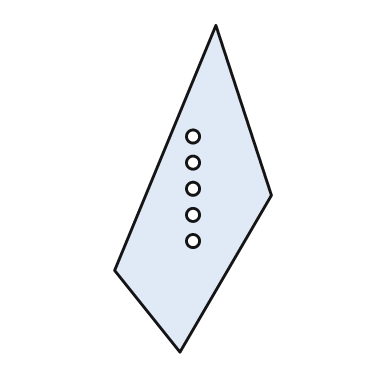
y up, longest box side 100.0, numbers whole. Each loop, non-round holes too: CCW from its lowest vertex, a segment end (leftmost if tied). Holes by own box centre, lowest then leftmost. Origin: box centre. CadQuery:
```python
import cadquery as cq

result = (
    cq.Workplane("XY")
    .moveTo(-4.0, -50.0)
    .lineTo(24.0, -2.0)
    .lineTo(7.0, 50.0)
    .lineTo(-24.0, -25.0)
    .close()
    .moveTo(0.0, -16.0)
    .circle(2.0)
    .moveTo(0.0, -8.0)
    .circle(2.0)
    .moveTo(0.0, 0.0)
    .circle(2.0)
    .moveTo(0.0, 8.0)
    .circle(2.0)
    .moveTo(0.0, 16.0)
    .circle(2.0)
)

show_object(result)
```